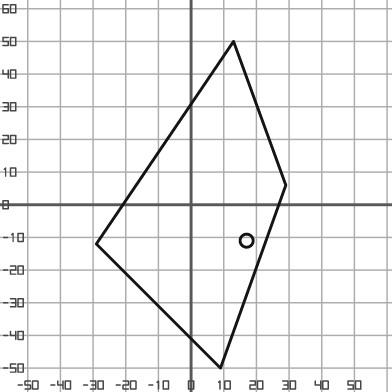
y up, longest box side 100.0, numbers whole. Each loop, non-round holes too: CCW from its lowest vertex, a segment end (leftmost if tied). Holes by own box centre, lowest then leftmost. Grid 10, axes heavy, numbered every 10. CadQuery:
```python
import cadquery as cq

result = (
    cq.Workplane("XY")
    .moveTo(9.0, -50.0)
    .lineTo(29.0, 6.0)
    .lineTo(13.0, 50.0)
    .lineTo(-29.0, -12.0)
    .close()
    .moveTo(17.0, -11.0)
    .circle(2.0)
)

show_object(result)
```